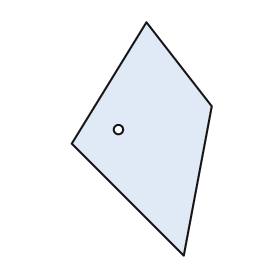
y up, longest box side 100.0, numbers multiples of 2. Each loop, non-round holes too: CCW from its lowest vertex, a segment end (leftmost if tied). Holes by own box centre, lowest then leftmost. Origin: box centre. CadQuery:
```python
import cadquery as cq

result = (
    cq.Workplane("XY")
    .moveTo(18.0, -50.0)
    .lineTo(30.0, 14.0)
    .lineTo(2.0, 50.0)
    .lineTo(-30.0, -2.0)
    .close()
    .moveTo(-10.0, 4.0)
    .circle(2.0)
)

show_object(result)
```